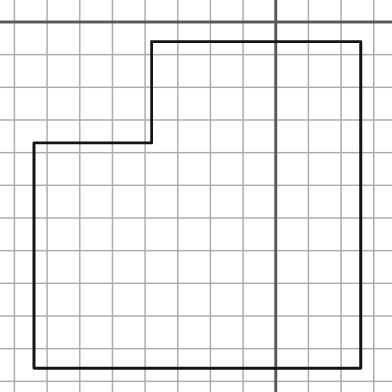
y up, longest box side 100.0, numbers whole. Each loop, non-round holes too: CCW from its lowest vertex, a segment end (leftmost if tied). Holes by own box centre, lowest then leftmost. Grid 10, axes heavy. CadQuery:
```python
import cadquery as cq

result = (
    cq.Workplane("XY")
    .moveTo(-74.0, -106.0)
    .lineTo(26.0, -106.0)
    .lineTo(26.0, -6.0)
    .lineTo(-38.0, -6.0)
    .lineTo(-38.0, -37.0)
    .lineTo(-74.0, -37.0)
    .close()
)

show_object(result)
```